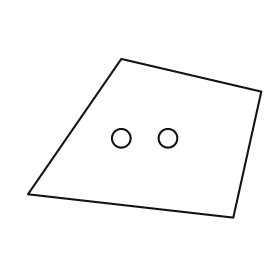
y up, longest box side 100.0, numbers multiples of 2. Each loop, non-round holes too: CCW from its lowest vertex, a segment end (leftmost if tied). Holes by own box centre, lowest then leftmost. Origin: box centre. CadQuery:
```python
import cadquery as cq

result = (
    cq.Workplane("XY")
    .moveTo(38.0, -34.0)
    .lineTo(50.0, 20.0)
    .lineTo(-10.0, 34.0)
    .lineTo(-50.0, -24.0)
    .close()
    .moveTo(-10.0, 0.0)
    .circle(4.0)
    .moveTo(10.0, 0.0)
    .circle(4.0)
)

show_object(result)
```